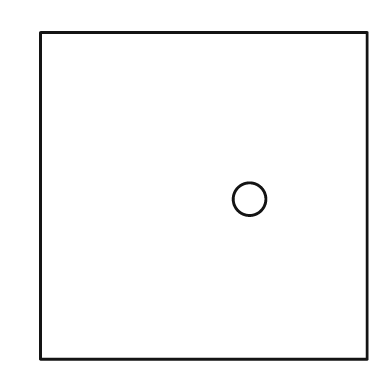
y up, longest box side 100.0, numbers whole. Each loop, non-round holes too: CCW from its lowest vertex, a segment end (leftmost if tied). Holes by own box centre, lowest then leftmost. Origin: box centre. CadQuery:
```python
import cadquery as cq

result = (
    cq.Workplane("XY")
    .moveTo(-50.0, -50.0)
    .lineTo(50.0, -50.0)
    .lineTo(50.0, 50.0)
    .lineTo(-50.0, 50.0)
    .close()
    .moveTo(14.0, -1.0)
    .circle(5.0)
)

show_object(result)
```